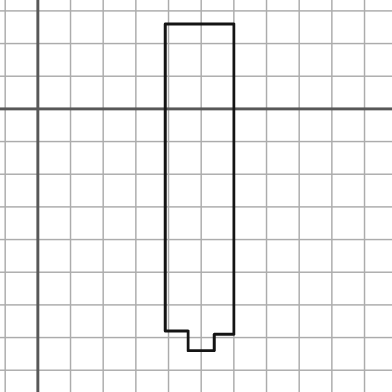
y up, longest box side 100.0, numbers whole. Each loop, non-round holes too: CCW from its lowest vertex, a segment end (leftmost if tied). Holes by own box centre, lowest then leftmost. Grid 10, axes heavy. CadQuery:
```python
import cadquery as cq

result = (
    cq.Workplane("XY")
    .moveTo(46.0, -74.0)
    .lineTo(54.0, -74.0)
    .lineTo(54.0, -69.0)
    .lineTo(60.0, -69.0)
    .lineTo(60.0, 26.0)
    .lineTo(39.0, 26.0)
    .lineTo(39.0, -68.0)
    .lineTo(46.0, -68.0)
    .close()
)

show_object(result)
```